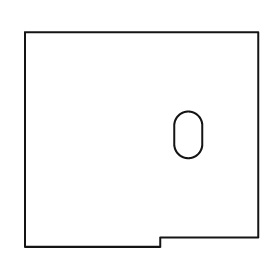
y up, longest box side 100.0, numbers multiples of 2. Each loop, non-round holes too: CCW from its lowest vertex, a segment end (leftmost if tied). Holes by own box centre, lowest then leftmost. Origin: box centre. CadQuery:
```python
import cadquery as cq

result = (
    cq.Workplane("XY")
    .moveTo(-50.0, -46.0)
    .lineTo(8.0, -46.0)
    .lineTo(8.0, -42.0)
    .lineTo(50.0, -42.0)
    .lineTo(50.0, 46.0)
    .lineTo(-50.0, 46.0)
    .close()
    .moveTo(14.0, -2.0)
    .threePointArc((20.0, -8.0), (26.0, -2.0))
    .lineTo(26.0, 6.0)
    .threePointArc((20.0, 12.0), (14.0, 6.0))
    .close()
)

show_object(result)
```